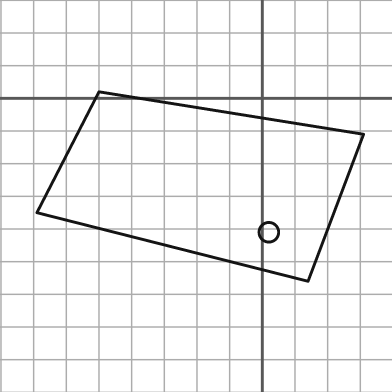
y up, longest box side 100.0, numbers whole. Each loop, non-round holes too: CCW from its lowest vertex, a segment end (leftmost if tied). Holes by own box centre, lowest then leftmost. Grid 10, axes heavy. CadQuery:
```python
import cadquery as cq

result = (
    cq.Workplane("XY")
    .moveTo(14.0, -56.0)
    .lineTo(31.0, -11.0)
    .lineTo(-50.0, 2.0)
    .lineTo(-69.0, -35.0)
    .close()
    .moveTo(2.0, -41.0)
    .circle(3.0)
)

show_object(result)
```